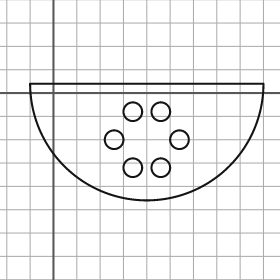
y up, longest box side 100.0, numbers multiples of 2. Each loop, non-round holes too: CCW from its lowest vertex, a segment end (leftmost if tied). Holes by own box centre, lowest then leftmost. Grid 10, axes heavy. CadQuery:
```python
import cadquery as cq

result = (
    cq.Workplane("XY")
    .moveTo(-10.0, 4.0)
    .threePointArc((40.0, -46.0), (90.0, 4.0))
    .close()
    .moveTo(34.0, -32.0)
    .circle(4.0)
    .moveTo(46.0, -32.0)
    .circle(4.0)
    .moveTo(26.0, -20.0)
    .circle(4.0)
    .moveTo(54.0, -20.0)
    .circle(4.0)
    .moveTo(34.0, -8.0)
    .circle(4.0)
    .moveTo(46.0, -8.0)
    .circle(4.0)
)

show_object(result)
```